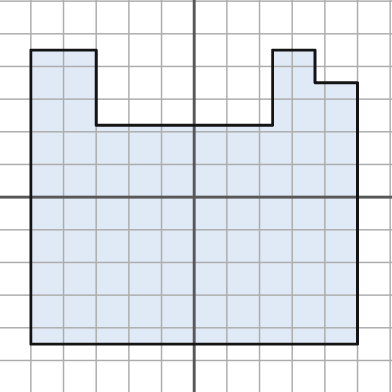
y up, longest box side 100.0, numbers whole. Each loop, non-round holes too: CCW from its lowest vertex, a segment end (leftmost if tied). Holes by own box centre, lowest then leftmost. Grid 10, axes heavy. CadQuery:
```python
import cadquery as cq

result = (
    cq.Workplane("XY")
    .moveTo(-50.0, -45.0)
    .lineTo(50.0, -45.0)
    .lineTo(50.0, 35.0)
    .lineTo(37.0, 35.0)
    .lineTo(37.0, 45.0)
    .lineTo(24.0, 45.0)
    .lineTo(24.0, 22.0)
    .lineTo(-30.0, 22.0)
    .lineTo(-30.0, 45.0)
    .lineTo(-50.0, 45.0)
    .close()
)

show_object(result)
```